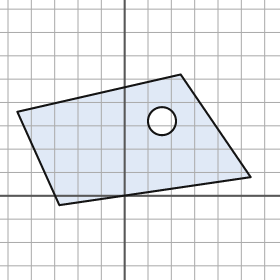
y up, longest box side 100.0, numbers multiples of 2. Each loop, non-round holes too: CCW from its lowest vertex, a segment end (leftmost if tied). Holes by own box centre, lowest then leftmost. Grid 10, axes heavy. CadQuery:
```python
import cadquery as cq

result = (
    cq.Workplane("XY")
    .moveTo(-28.0, -4.0)
    .lineTo(54.0, 8.0)
    .lineTo(24.0, 52.0)
    .lineTo(-46.0, 36.0)
    .close()
    .moveTo(16.0, 32.0)
    .circle(6.0)
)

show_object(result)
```